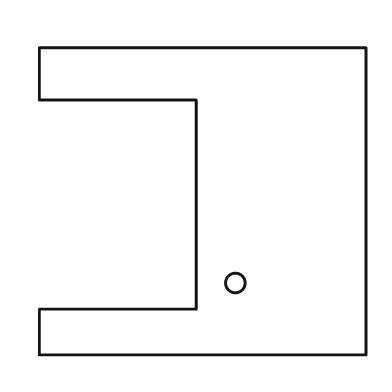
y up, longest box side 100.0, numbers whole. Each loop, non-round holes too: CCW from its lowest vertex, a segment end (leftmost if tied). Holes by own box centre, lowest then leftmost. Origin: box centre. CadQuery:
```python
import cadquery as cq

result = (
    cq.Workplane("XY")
    .moveTo(-50.0, -47.0)
    .lineTo(50.0, -47.0)
    .lineTo(50.0, 47.0)
    .lineTo(-50.0, 47.0)
    .lineTo(-50.0, 31.0)
    .lineTo(-2.0, 31.0)
    .lineTo(-2.0, -33.0)
    .lineTo(-50.0, -33.0)
    .close()
    .moveTo(10.0, -25.0)
    .circle(3.0)
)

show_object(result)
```